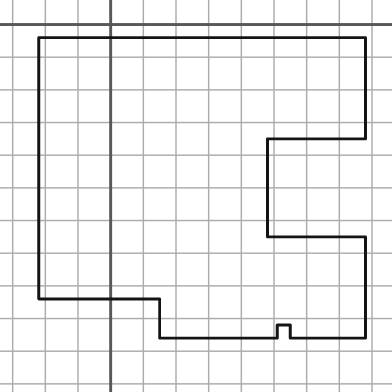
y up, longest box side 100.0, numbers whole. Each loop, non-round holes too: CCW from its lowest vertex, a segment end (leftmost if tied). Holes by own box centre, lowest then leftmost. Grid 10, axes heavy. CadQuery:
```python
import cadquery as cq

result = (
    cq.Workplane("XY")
    .moveTo(15.0, -96.0)
    .lineTo(51.0, -96.0)
    .lineTo(51.0, -92.0)
    .lineTo(55.0, -92.0)
    .lineTo(55.0, -96.0)
    .lineTo(78.0, -96.0)
    .lineTo(78.0, -65.0)
    .lineTo(48.0, -65.0)
    .lineTo(48.0, -35.0)
    .lineTo(78.0, -35.0)
    .lineTo(78.0, -4.0)
    .lineTo(-22.0, -4.0)
    .lineTo(-22.0, -84.0)
    .lineTo(15.0, -84.0)
    .close()
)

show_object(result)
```